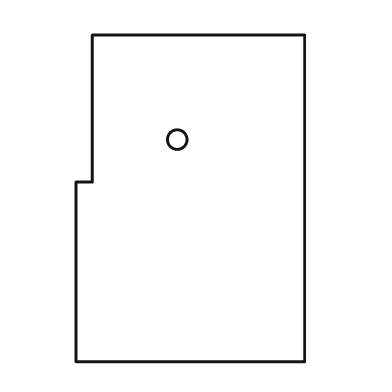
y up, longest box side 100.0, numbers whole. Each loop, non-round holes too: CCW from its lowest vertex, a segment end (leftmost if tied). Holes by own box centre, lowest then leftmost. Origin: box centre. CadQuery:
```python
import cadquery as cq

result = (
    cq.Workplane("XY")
    .moveTo(-35.0, -50.0)
    .lineTo(35.0, -50.0)
    .lineTo(35.0, 50.0)
    .lineTo(-30.0, 50.0)
    .lineTo(-30.0, 5.0)
    .lineTo(-35.0, 5.0)
    .close()
    .moveTo(-4.0, 18.0)
    .circle(3.0)
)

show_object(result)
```